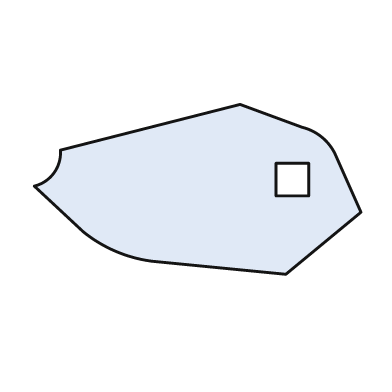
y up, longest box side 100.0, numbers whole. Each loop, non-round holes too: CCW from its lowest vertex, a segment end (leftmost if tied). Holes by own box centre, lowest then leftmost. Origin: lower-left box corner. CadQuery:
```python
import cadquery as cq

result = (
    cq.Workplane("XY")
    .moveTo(77.0, 0.0)
    .lineTo(100.0, 19.0)
    .lineTo(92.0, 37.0)
    .threePointArc((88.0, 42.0), (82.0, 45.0))
    .lineTo(63.0, 52.0)
    .lineTo(8.0, 38.0)
    .threePointArc((6.0, 31.0), (0.0, 27.0))
    .lineTo(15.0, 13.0)
    .threePointArc((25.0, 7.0), (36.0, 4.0))
    .close()
    .moveTo(74.0, 24.0)
    .lineTo(84.0, 24.0)
    .lineTo(84.0, 34.0)
    .lineTo(74.0, 34.0)
    .close()
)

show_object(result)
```